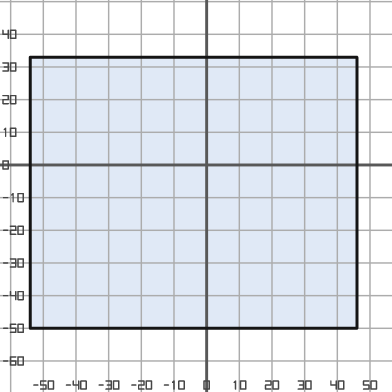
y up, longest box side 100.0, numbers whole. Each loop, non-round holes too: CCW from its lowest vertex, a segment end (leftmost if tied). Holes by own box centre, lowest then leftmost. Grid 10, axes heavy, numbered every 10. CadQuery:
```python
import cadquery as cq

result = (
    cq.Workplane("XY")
    .moveTo(-54.0, -50.0)
    .lineTo(46.0, -50.0)
    .lineTo(46.0, 33.0)
    .lineTo(-54.0, 33.0)
    .close()
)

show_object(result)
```